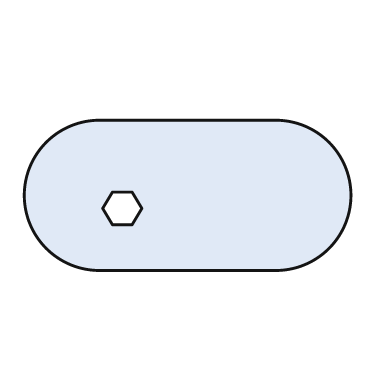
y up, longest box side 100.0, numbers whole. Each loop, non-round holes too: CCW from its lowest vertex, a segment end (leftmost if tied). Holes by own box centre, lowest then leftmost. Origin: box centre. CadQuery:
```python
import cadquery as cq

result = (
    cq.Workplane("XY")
    .moveTo(-27.0, -23.0)
    .lineTo(27.0, -23.0)
    .threePointArc((50.0, 0.0), (27.0, 23.0))
    .lineTo(-27.0, 23.0)
    .threePointArc((-50.0, 0.0), (-27.0, -23.0))
    .close()
    .moveTo(-23.0, -9.0)
    .lineTo(-17.0, -9.0)
    .lineTo(-14.0, -4.0)
    .lineTo(-17.0, 1.0)
    .lineTo(-23.0, 1.0)
    .lineTo(-26.0, -4.0)
    .close()
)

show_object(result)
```